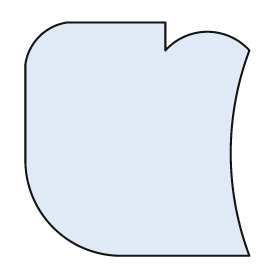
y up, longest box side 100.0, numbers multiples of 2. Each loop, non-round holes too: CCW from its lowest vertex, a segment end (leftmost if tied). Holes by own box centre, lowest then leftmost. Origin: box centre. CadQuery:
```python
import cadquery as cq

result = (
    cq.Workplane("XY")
    .moveTo(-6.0, -50.0)
    .lineTo(48.0, -50.0)
    .threePointArc((40.0, -6.0), (48.0, 38.0))
    .threePointArc((30.0, 46.0), (12.0, 38.0))
    .lineTo(12.0, 50.0)
    .lineTo(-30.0, 50.0)
    .threePointArc((-42.0, 44.0), (-48.0, 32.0))
    .lineTo(-48.0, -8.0)
    .threePointArc((-36.0, -38.0), (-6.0, -50.0))
    .close()
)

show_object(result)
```